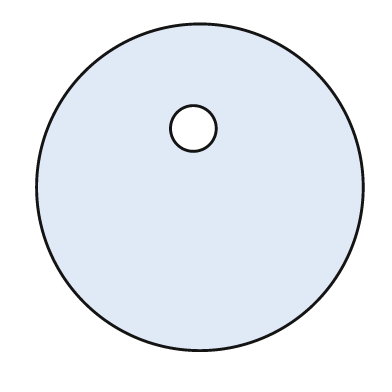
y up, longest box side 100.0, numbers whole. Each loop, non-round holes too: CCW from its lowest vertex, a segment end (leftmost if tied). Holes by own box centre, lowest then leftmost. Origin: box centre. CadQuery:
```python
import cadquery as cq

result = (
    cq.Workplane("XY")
    .moveTo(0.0, 0.0)
    .circle(50.0)
    .moveTo(-2.0, 18.0)
    .circle(7.0)
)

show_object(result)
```